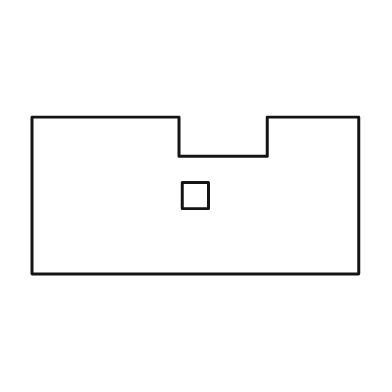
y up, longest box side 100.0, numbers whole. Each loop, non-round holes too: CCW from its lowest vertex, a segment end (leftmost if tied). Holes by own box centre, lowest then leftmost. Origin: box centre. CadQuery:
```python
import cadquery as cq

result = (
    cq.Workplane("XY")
    .moveTo(-50.0, -24.0)
    .lineTo(50.0, -24.0)
    .lineTo(50.0, 24.0)
    .lineTo(22.0, 24.0)
    .lineTo(22.0, 12.0)
    .lineTo(-5.0, 12.0)
    .lineTo(-5.0, 24.0)
    .lineTo(-50.0, 24.0)
    .close()
    .moveTo(-4.0, -4.0)
    .lineTo(4.0, -4.0)
    .lineTo(4.0, 4.0)
    .lineTo(-4.0, 4.0)
    .close()
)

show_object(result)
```